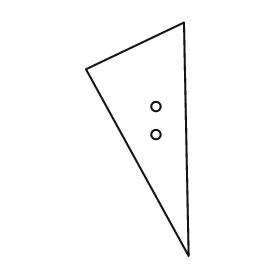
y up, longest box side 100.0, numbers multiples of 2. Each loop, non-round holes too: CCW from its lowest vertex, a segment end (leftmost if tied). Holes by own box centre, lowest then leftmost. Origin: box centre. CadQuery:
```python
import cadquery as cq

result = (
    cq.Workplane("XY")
    .moveTo(22.0, -50.0)
    .lineTo(20.0, 50.0)
    .lineTo(-22.0, 30.0)
    .close()
    .moveTo(8.0, 2.0)
    .circle(2.0)
    .moveTo(8.0, 14.0)
    .circle(2.0)
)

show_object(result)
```